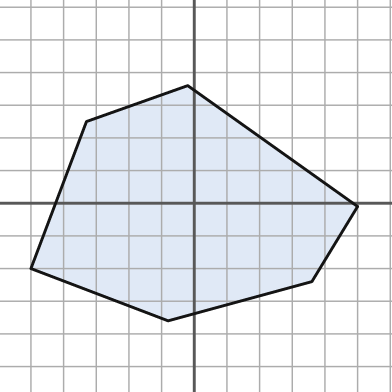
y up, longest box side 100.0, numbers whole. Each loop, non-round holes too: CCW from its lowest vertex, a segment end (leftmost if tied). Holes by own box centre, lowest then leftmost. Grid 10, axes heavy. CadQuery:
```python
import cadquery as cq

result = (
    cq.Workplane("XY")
    .moveTo(-8.0, -36.0)
    .lineTo(36.0, -24.0)
    .lineTo(50.0, -1.0)
    .lineTo(-2.0, 36.0)
    .lineTo(-33.0, 25.0)
    .lineTo(-50.0, -20.0)
    .close()
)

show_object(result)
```